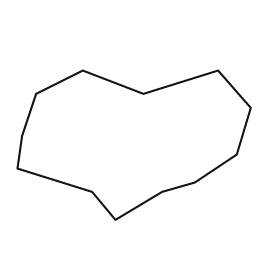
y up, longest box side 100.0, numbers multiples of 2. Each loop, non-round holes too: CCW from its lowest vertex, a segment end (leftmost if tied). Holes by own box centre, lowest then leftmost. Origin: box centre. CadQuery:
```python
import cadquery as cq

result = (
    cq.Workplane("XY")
    .moveTo(-8.0, -32.0)
    .lineTo(12.0, -20.0)
    .lineTo(26.0, -16.0)
    .lineTo(44.0, -4.0)
    .lineTo(50.0, 16.0)
    .lineTo(36.0, 32.0)
    .lineTo(4.0, 22.0)
    .lineTo(-22.0, 32.0)
    .lineTo(-42.0, 22.0)
    .lineTo(-48.0, 4.0)
    .lineTo(-50.0, -10.0)
    .lineTo(-18.0, -20.0)
    .close()
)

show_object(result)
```